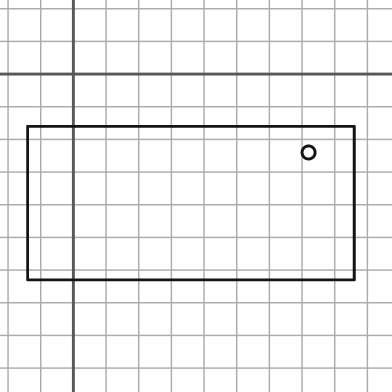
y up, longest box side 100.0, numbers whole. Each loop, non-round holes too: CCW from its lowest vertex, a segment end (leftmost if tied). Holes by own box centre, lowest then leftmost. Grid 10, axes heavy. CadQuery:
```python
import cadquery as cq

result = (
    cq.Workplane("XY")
    .moveTo(-14.0, -63.0)
    .lineTo(86.0, -63.0)
    .lineTo(86.0, -16.0)
    .lineTo(-14.0, -16.0)
    .close()
    .moveTo(72.0, -24.0)
    .circle(2.0)
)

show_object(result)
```